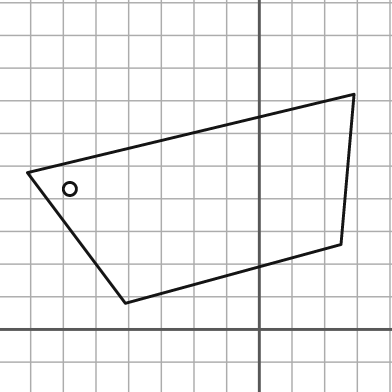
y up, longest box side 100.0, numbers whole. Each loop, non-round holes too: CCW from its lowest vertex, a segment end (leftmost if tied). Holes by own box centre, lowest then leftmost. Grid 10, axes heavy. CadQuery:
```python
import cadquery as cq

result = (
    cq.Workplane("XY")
    .moveTo(-41.0, 8.0)
    .lineTo(25.0, 26.0)
    .lineTo(29.0, 72.0)
    .lineTo(-71.0, 48.0)
    .close()
    .moveTo(-58.0, 43.0)
    .circle(2.0)
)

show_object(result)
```